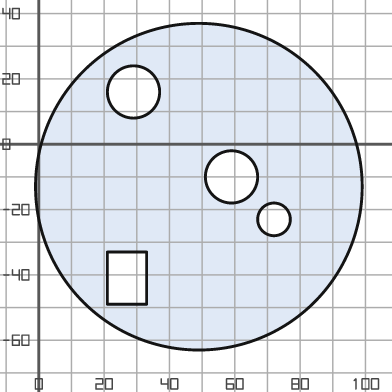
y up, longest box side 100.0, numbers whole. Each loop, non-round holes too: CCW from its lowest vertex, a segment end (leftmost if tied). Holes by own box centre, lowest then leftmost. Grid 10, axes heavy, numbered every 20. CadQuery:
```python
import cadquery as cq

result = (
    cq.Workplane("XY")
    .moveTo(49.0, -13.0)
    .circle(50.0)
    .moveTo(21.0, -49.0)
    .lineTo(33.0, -49.0)
    .lineTo(33.0, -33.0)
    .lineTo(21.0, -33.0)
    .close()
    .moveTo(72.0, -23.0)
    .circle(5.0)
    .moveTo(59.0, -10.0)
    .circle(8.0)
    .moveTo(29.0, 16.0)
    .circle(8.0)
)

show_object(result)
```